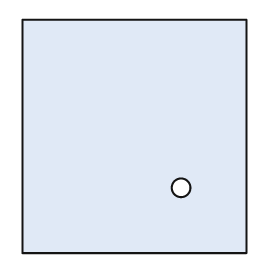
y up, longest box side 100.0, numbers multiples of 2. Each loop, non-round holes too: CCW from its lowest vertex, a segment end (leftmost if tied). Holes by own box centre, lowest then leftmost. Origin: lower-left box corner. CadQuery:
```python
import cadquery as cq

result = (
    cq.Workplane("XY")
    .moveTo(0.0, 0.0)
    .lineTo(96.0, 0.0)
    .lineTo(96.0, 100.0)
    .lineTo(0.0, 100.0)
    .close()
    .moveTo(68.0, 28.0)
    .circle(4.0)
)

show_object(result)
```